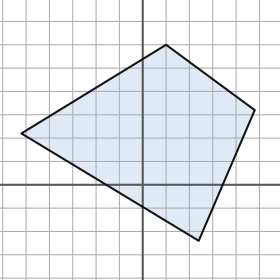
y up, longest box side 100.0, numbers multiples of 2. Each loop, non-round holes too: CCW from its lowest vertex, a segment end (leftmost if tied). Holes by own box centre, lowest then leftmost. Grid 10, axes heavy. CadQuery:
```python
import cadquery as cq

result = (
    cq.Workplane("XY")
    .moveTo(24.0, -24.0)
    .lineTo(48.0, 32.0)
    .lineTo(10.0, 60.0)
    .lineTo(-52.0, 22.0)
    .close()
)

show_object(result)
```